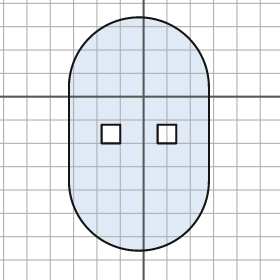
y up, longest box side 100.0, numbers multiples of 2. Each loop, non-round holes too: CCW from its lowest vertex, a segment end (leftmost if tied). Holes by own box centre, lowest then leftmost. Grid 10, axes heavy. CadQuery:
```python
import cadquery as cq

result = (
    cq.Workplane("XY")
    .moveTo(-32.0, -36.0)
    .threePointArc((-2.0, -66.0), (28.0, -36.0))
    .lineTo(28.0, 4.0)
    .threePointArc((-2.0, 34.0), (-32.0, 4.0))
    .close()
    .moveTo(-18.0, -20.0)
    .lineTo(-10.0, -20.0)
    .lineTo(-10.0, -12.0)
    .lineTo(-18.0, -12.0)
    .close()
    .moveTo(6.0, -20.0)
    .lineTo(14.0, -20.0)
    .lineTo(14.0, -12.0)
    .lineTo(6.0, -12.0)
    .close()
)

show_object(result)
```